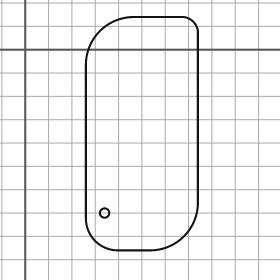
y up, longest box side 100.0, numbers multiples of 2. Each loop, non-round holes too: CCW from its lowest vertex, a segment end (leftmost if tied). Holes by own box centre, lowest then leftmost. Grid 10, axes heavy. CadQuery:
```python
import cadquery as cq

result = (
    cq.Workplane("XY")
    .moveTo(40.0, -86.0)
    .lineTo(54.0, -86.0)
    .threePointArc((68.0, -80.0), (74.0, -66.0))
    .lineTo(74.0, 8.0)
    .threePointArc((72.0, 12.0), (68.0, 14.0))
    .lineTo(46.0, 14.0)
    .threePointArc((32.0, 8.0), (26.0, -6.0))
    .lineTo(26.0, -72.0)
    .threePointArc((30.0, -82.0), (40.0, -86.0))
    .close()
    .moveTo(34.0, -70.0)
    .circle(2.0)
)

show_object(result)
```